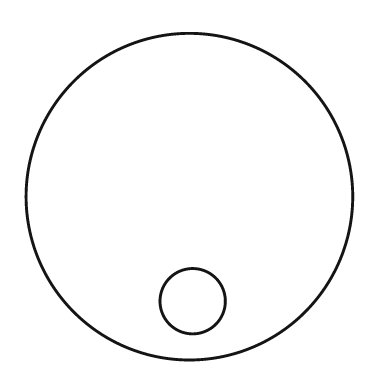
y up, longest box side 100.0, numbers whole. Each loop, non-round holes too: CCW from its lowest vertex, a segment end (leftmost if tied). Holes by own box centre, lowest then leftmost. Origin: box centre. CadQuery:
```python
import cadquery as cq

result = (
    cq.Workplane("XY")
    .moveTo(0.0, 0.0)
    .circle(50.0)
    .moveTo(1.0, -32.0)
    .circle(10.0)
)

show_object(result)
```